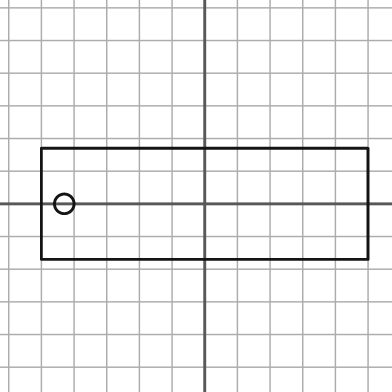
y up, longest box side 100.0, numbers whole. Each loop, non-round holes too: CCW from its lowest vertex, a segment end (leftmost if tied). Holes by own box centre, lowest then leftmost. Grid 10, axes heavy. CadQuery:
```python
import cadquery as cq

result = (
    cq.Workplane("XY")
    .moveTo(-50.0, -17.0)
    .lineTo(50.0, -17.0)
    .lineTo(50.0, 17.0)
    .lineTo(-50.0, 17.0)
    .close()
    .moveTo(-43.0, 0.0)
    .circle(3.0)
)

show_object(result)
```